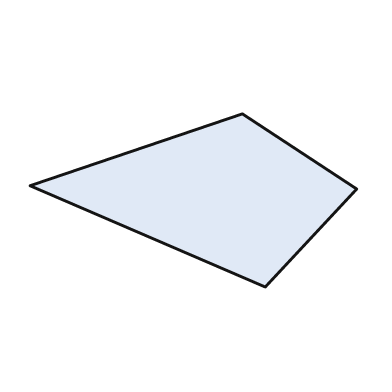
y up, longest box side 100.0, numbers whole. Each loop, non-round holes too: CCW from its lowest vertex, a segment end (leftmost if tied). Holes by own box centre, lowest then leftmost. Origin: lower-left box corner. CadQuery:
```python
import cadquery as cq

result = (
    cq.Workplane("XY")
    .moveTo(72.0, 0.0)
    .lineTo(100.0, 30.0)
    .lineTo(65.0, 53.0)
    .lineTo(0.0, 31.0)
    .close()
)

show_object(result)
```